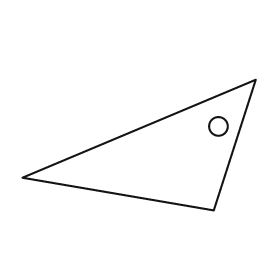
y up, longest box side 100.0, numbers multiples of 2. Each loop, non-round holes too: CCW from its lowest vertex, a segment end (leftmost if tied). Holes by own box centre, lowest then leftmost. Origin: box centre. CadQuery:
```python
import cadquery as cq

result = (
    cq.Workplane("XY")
    .moveTo(32.0, -28.0)
    .lineTo(50.0, 28.0)
    .lineTo(-50.0, -14.0)
    .close()
    .moveTo(34.0, 8.0)
    .circle(4.0)
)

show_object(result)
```